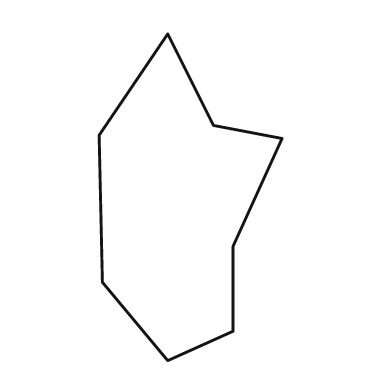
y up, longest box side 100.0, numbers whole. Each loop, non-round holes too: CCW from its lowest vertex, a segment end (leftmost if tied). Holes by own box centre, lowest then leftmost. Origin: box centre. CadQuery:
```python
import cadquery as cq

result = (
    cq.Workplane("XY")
    .moveTo(-7.0, -50.0)
    .lineTo(13.0, -41.0)
    .lineTo(13.0, -15.0)
    .lineTo(28.0, 18.0)
    .lineTo(7.0, 22.0)
    .lineTo(-7.0, 50.0)
    .lineTo(-28.0, 19.0)
    .lineTo(-27.0, -26.0)
    .close()
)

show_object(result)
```